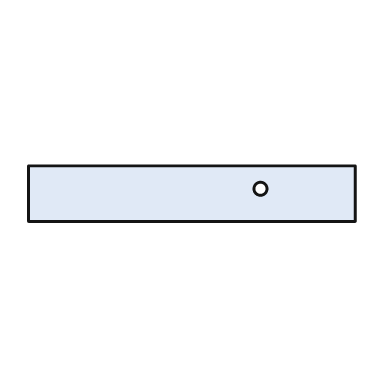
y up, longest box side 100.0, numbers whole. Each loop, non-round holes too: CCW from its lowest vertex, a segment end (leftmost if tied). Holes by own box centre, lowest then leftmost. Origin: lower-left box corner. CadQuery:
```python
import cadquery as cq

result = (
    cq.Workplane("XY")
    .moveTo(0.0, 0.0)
    .lineTo(100.0, 0.0)
    .lineTo(100.0, 17.0)
    .lineTo(0.0, 17.0)
    .close()
    .moveTo(71.0, 10.0)
    .circle(2.0)
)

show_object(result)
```